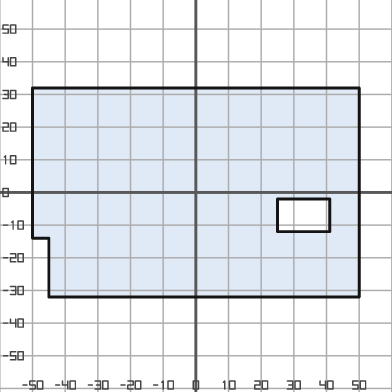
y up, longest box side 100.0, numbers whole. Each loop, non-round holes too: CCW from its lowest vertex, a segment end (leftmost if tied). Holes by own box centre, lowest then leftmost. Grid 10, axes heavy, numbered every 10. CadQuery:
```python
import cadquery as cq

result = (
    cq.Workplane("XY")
    .moveTo(-45.0, -32.0)
    .lineTo(50.0, -32.0)
    .lineTo(50.0, 32.0)
    .lineTo(-50.0, 32.0)
    .lineTo(-50.0, -14.0)
    .lineTo(-45.0, -14.0)
    .close()
    .moveTo(25.0, -12.0)
    .lineTo(41.0, -12.0)
    .lineTo(41.0, -2.0)
    .lineTo(25.0, -2.0)
    .close()
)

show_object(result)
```